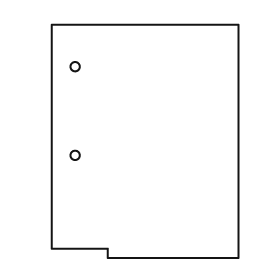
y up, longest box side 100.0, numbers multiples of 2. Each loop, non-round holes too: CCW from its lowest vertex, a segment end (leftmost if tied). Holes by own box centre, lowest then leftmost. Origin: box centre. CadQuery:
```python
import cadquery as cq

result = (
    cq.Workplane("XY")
    .moveTo(-16.0, -50.0)
    .lineTo(40.0, -50.0)
    .lineTo(40.0, 50.0)
    .lineTo(-40.0, 50.0)
    .lineTo(-40.0, -46.0)
    .lineTo(-16.0, -46.0)
    .close()
    .moveTo(-30.0, -6.0)
    .circle(2.0)
    .moveTo(-30.0, 32.0)
    .circle(2.0)
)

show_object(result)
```